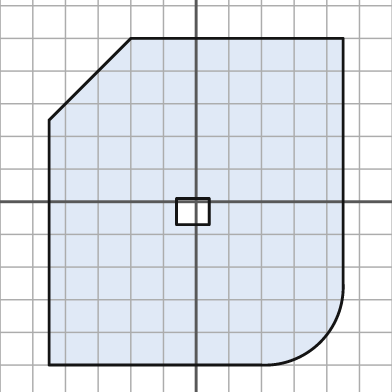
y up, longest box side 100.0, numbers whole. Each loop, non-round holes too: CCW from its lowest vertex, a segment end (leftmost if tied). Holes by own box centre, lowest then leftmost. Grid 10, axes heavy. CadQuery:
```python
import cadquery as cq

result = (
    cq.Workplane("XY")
    .moveTo(-45.0, -50.0)
    .lineTo(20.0, -50.0)
    .threePointArc((38.0, -43.0), (45.0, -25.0))
    .lineTo(45.0, 50.0)
    .lineTo(-20.0, 50.0)
    .lineTo(-45.0, 25.0)
    .close()
    .moveTo(-6.0, -7.0)
    .lineTo(4.0, -7.0)
    .lineTo(4.0, 1.0)
    .lineTo(-6.0, 1.0)
    .close()
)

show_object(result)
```